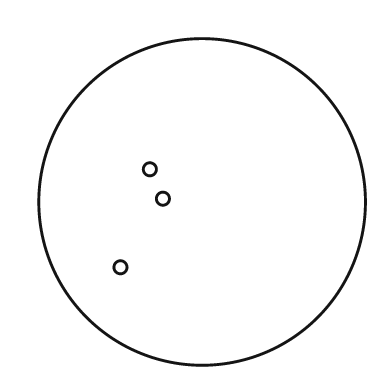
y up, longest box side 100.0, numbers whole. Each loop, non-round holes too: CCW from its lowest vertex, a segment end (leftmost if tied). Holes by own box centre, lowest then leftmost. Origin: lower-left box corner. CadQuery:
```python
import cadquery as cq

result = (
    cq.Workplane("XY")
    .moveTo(50.0, 50.0)
    .circle(50.0)
    .moveTo(25.0, 30.0)
    .circle(2.0)
    .moveTo(38.0, 51.0)
    .circle(2.0)
    .moveTo(34.0, 60.0)
    .circle(2.0)
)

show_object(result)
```